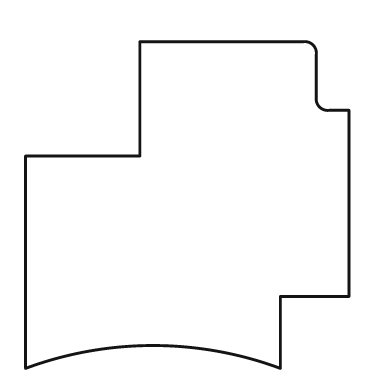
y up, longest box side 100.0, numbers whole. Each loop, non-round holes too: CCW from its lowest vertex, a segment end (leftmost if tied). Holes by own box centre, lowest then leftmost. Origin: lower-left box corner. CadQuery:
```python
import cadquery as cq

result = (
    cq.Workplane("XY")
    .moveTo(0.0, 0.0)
    .threePointArc((39.0, 7.0), (78.0, 0.0))
    .lineTo(78.0, 22.0)
    .lineTo(99.0, 22.0)
    .lineTo(99.0, 79.0)
    .lineTo(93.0, 79.0)
    .threePointArc((90.0, 80.0), (89.0, 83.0))
    .lineTo(89.0, 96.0)
    .threePointArc((88.0, 99.0), (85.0, 100.0))
    .lineTo(35.0, 100.0)
    .lineTo(35.0, 65.0)
    .lineTo(0.0, 65.0)
    .close()
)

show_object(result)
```